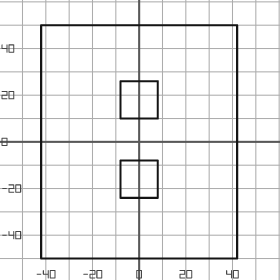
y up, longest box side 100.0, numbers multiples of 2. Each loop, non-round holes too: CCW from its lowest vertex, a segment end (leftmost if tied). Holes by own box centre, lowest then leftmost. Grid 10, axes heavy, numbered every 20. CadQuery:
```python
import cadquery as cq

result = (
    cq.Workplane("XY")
    .moveTo(-42.0, -50.0)
    .lineTo(42.0, -50.0)
    .lineTo(42.0, 50.0)
    .lineTo(-42.0, 50.0)
    .close()
    .moveTo(-8.0, -24.0)
    .lineTo(8.0, -24.0)
    .lineTo(8.0, -8.0)
    .lineTo(-8.0, -8.0)
    .close()
    .moveTo(-8.0, 10.0)
    .lineTo(8.0, 10.0)
    .lineTo(8.0, 26.0)
    .lineTo(-8.0, 26.0)
    .close()
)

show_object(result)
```